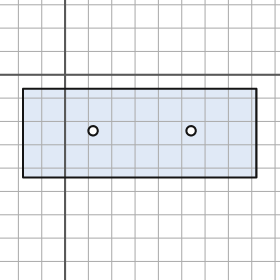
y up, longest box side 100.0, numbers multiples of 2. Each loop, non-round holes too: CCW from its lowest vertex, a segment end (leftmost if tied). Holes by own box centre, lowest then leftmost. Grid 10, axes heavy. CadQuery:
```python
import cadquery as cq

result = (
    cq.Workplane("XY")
    .moveTo(-18.0, -44.0)
    .lineTo(82.0, -44.0)
    .lineTo(82.0, -6.0)
    .lineTo(-18.0, -6.0)
    .close()
    .moveTo(12.0, -24.0)
    .circle(2.0)
    .moveTo(54.0, -24.0)
    .circle(2.0)
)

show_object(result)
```